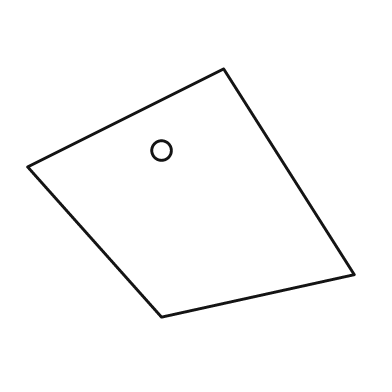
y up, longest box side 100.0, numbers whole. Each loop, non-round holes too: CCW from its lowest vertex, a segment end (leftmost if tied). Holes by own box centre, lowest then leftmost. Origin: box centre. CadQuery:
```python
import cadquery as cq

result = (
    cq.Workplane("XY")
    .moveTo(-9.0, -38.0)
    .lineTo(50.0, -25.0)
    .lineTo(10.0, 38.0)
    .lineTo(-50.0, 8.0)
    .close()
    .moveTo(-9.0, 13.0)
    .circle(3.0)
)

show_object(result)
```